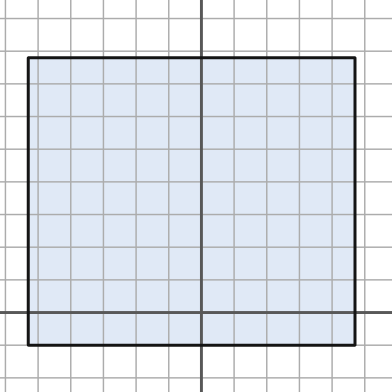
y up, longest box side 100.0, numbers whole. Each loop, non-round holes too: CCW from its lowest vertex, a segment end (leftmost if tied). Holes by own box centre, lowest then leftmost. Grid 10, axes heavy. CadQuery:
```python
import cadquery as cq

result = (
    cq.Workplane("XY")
    .moveTo(-53.0, -10.0)
    .lineTo(47.0, -10.0)
    .lineTo(47.0, 78.0)
    .lineTo(-53.0, 78.0)
    .close()
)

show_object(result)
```